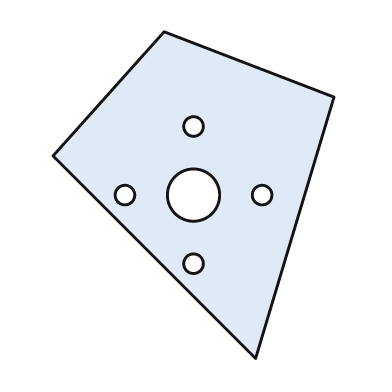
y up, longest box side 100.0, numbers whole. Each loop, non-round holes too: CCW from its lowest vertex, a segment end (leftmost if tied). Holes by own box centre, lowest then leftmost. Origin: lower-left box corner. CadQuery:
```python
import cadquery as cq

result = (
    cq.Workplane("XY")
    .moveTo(62.0, 0.0)
    .lineTo(86.0, 80.0)
    .lineTo(34.0, 100.0)
    .lineTo(0.0, 62.0)
    .close()
    .moveTo(43.0, 29.0)
    .circle(3.0)
    .moveTo(22.0, 50.0)
    .circle(3.0)
    .moveTo(43.0, 50.0)
    .circle(8.0)
    .moveTo(64.0, 50.0)
    .circle(3.0)
    .moveTo(43.0, 71.0)
    .circle(3.0)
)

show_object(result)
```